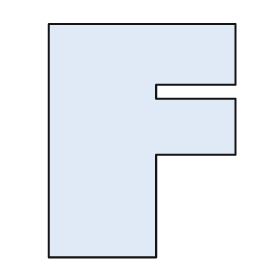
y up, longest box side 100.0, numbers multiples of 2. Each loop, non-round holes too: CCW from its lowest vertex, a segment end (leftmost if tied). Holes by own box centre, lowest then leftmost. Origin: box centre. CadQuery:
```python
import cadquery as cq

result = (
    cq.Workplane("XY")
    .moveTo(-40.0, -50.0)
    .lineTo(6.0, -50.0)
    .lineTo(6.0, -6.0)
    .lineTo(40.0, -6.0)
    .lineTo(40.0, 18.0)
    .lineTo(6.0, 18.0)
    .lineTo(6.0, 24.0)
    .lineTo(40.0, 24.0)
    .lineTo(40.0, 50.0)
    .lineTo(-40.0, 50.0)
    .close()
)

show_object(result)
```